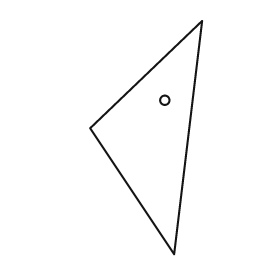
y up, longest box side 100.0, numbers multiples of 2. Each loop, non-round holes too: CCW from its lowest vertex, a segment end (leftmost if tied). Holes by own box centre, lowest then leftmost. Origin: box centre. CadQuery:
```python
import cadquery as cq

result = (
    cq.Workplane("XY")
    .moveTo(12.0, -50.0)
    .lineTo(24.0, 50.0)
    .lineTo(-24.0, 4.0)
    .close()
    .moveTo(8.0, 16.0)
    .circle(2.0)
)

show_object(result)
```